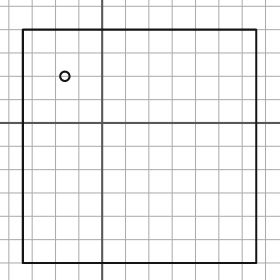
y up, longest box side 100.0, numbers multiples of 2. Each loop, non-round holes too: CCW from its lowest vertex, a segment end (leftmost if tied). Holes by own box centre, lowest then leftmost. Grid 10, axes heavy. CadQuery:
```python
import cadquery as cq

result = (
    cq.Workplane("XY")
    .moveTo(-34.0, -60.0)
    .lineTo(66.0, -60.0)
    .lineTo(66.0, 40.0)
    .lineTo(-34.0, 40.0)
    .close()
    .moveTo(-16.0, 20.0)
    .circle(2.0)
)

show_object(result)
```